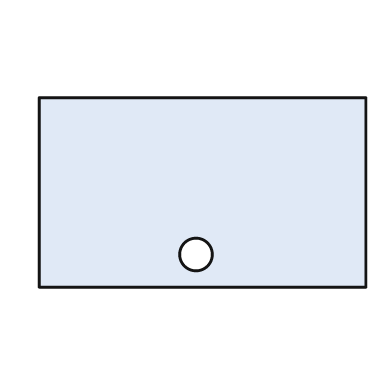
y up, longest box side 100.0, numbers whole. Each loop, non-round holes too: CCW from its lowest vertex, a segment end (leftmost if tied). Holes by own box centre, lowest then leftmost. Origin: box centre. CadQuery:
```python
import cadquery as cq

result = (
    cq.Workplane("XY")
    .moveTo(-50.0, -29.0)
    .lineTo(50.0, -29.0)
    .lineTo(50.0, 29.0)
    .lineTo(-50.0, 29.0)
    .close()
    .moveTo(-2.0, -19.0)
    .circle(5.0)
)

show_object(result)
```